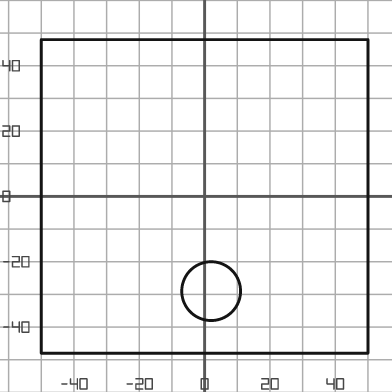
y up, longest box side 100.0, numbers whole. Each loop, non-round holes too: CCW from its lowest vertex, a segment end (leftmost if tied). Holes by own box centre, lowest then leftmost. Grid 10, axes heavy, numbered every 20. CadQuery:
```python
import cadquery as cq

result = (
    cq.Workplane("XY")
    .moveTo(-50.0, -48.0)
    .lineTo(50.0, -48.0)
    .lineTo(50.0, 48.0)
    .lineTo(-50.0, 48.0)
    .close()
    .moveTo(2.0, -29.0)
    .circle(9.0)
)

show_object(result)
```